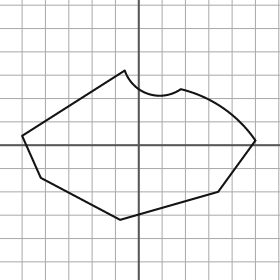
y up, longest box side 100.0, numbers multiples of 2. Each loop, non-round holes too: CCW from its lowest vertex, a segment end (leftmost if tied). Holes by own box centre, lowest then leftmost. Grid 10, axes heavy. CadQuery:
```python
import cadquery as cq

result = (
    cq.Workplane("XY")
    .moveTo(-8.0, -32.0)
    .lineTo(34.0, -20.0)
    .lineTo(50.0, 2.0)
    .threePointArc((36.0, 16.0), (18.0, 24.0))
    .threePointArc((4.0, 22.0), (-6.0, 32.0))
    .lineTo(-50.0, 4.0)
    .lineTo(-42.0, -14.0)
    .close()
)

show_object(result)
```